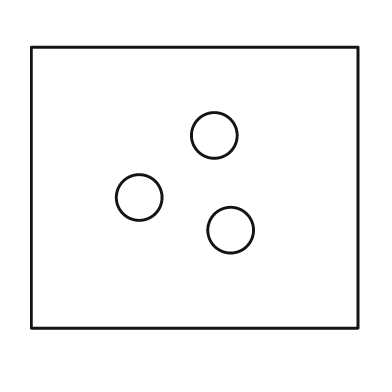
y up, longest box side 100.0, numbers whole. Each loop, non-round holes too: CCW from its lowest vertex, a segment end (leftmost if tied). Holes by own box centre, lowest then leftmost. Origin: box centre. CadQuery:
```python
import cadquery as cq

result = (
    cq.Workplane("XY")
    .moveTo(-50.0, -43.0)
    .lineTo(50.0, -43.0)
    .lineTo(50.0, 43.0)
    .lineTo(-50.0, 43.0)
    .close()
    .moveTo(11.0, -13.0)
    .circle(7.0)
    .moveTo(-17.0, -3.0)
    .circle(7.0)
    .moveTo(6.0, 16.0)
    .circle(7.0)
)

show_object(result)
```